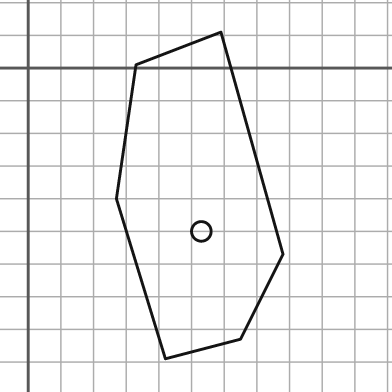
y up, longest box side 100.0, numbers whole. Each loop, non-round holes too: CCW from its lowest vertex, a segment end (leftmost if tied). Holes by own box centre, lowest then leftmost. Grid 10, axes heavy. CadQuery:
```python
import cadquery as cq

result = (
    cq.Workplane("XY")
    .moveTo(42.0, -89.0)
    .lineTo(65.0, -83.0)
    .lineTo(78.0, -57.0)
    .lineTo(59.0, 11.0)
    .lineTo(33.0, 1.0)
    .lineTo(27.0, -40.0)
    .close()
    .moveTo(53.0, -50.0)
    .circle(3.0)
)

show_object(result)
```